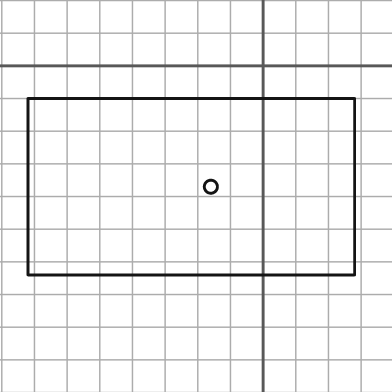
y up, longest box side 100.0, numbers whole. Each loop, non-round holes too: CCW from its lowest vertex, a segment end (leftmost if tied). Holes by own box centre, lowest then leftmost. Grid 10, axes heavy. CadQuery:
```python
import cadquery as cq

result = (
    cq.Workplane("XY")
    .moveTo(-72.0, -64.0)
    .lineTo(28.0, -64.0)
    .lineTo(28.0, -10.0)
    .lineTo(-72.0, -10.0)
    .close()
    .moveTo(-16.0, -37.0)
    .circle(2.0)
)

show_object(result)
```